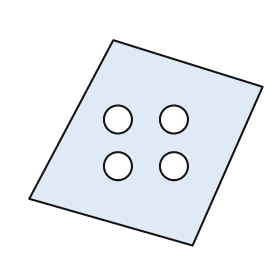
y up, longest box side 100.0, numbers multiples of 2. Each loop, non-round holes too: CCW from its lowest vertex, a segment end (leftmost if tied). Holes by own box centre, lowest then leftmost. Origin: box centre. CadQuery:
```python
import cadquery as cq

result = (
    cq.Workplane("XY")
    .moveTo(20.0, -44.0)
    .lineTo(50.0, 24.0)
    .lineTo(-14.0, 44.0)
    .lineTo(-50.0, -24.0)
    .close()
    .moveTo(-12.0, -10.0)
    .circle(6.0)
    .moveTo(12.0, -10.0)
    .circle(6.0)
    .moveTo(-12.0, 10.0)
    .circle(6.0)
    .moveTo(12.0, 10.0)
    .circle(6.0)
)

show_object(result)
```